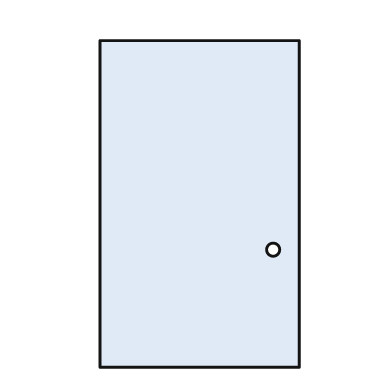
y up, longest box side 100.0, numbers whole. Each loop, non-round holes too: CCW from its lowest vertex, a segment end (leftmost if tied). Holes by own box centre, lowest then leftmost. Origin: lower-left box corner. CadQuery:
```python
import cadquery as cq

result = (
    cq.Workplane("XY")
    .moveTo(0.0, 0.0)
    .lineTo(61.0, 0.0)
    .lineTo(61.0, 100.0)
    .lineTo(0.0, 100.0)
    .close()
    .moveTo(53.0, 36.0)
    .circle(2.0)
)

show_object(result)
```